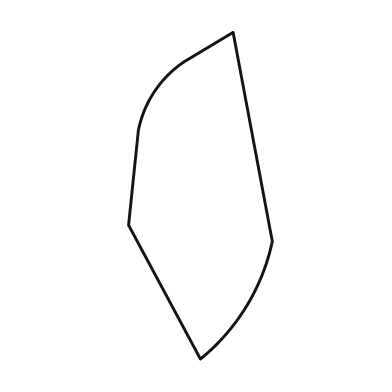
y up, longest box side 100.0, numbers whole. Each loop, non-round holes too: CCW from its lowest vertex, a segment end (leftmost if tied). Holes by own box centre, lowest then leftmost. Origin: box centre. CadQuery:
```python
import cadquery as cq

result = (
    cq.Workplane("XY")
    .moveTo(0.0, -50.0)
    .threePointArc((14.0, -34.0), (22.0, -14.0))
    .lineTo(10.0, 50.0)
    .lineTo(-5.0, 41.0)
    .threePointArc((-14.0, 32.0), (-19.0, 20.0))
    .lineTo(-22.0, -9.0)
    .close()
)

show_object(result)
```